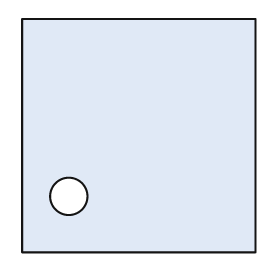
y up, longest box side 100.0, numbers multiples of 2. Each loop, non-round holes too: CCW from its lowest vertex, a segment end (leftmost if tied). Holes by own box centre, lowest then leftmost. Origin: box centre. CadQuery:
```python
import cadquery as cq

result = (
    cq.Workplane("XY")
    .moveTo(-50.0, -50.0)
    .lineTo(50.0, -50.0)
    .lineTo(50.0, 50.0)
    .lineTo(-50.0, 50.0)
    .close()
    .moveTo(-30.0, -26.0)
    .circle(8.0)
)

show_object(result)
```